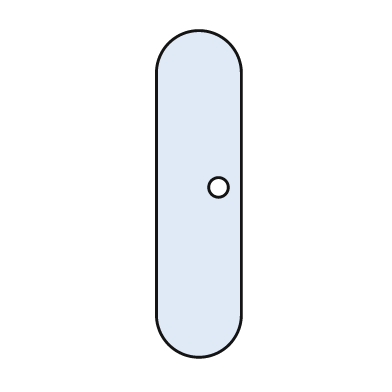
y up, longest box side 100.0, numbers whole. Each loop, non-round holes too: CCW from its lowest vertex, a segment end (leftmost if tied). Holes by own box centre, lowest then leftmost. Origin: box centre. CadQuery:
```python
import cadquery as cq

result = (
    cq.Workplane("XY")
    .moveTo(-13.0, -37.0)
    .threePointArc((0.0, -50.0), (13.0, -37.0))
    .lineTo(13.0, 37.0)
    .threePointArc((0.0, 50.0), (-13.0, 37.0))
    .close()
    .moveTo(6.0, 2.0)
    .circle(3.0)
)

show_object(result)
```